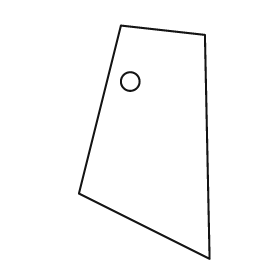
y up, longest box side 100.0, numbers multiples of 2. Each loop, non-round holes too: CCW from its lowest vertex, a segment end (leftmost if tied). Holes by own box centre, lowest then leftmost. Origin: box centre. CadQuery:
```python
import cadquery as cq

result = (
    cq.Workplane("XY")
    .moveTo(28.0, -50.0)
    .lineTo(26.0, 46.0)
    .lineTo(-10.0, 50.0)
    .lineTo(-28.0, -22.0)
    .close()
    .moveTo(-6.0, 26.0)
    .circle(4.0)
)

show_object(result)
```